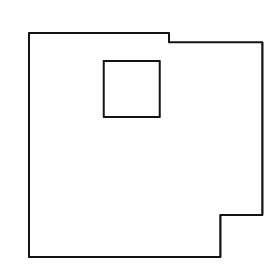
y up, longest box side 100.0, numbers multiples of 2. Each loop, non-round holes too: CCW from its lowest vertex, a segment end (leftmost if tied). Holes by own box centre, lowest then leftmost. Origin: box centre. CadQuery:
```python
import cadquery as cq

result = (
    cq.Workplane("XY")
    .moveTo(-50.0, -48.0)
    .lineTo(32.0, -48.0)
    .lineTo(32.0, -30.0)
    .lineTo(50.0, -30.0)
    .lineTo(50.0, 44.0)
    .lineTo(10.0, 44.0)
    .lineTo(10.0, 48.0)
    .lineTo(-50.0, 48.0)
    .close()
    .moveTo(-18.0, 12.0)
    .lineTo(6.0, 12.0)
    .lineTo(6.0, 36.0)
    .lineTo(-18.0, 36.0)
    .close()
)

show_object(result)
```